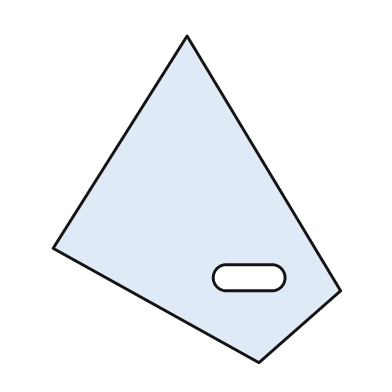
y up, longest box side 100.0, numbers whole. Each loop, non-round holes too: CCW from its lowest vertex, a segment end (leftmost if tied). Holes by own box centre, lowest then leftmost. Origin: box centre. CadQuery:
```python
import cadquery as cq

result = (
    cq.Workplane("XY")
    .moveTo(19.0, -50.0)
    .lineTo(44.0, -28.0)
    .lineTo(-3.0, 50.0)
    .lineTo(-44.0, -15.0)
    .close()
    .moveTo(9.0, -28.0)
    .lineTo(23.0, -28.0)
    .threePointArc((27.0, -24.0), (23.0, -20.0))
    .lineTo(9.0, -20.0)
    .threePointArc((5.0, -24.0), (9.0, -28.0))
    .close()
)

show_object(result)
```